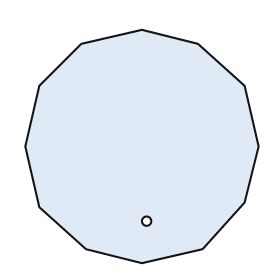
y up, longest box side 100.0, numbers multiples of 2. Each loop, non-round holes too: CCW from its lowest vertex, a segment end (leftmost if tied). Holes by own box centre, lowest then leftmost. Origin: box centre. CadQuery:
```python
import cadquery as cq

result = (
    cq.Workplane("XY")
    .moveTo(0.0, -50.0)
    .lineTo(26.0, -44.0)
    .lineTo(44.0, -24.0)
    .lineTo(50.0, 0.0)
    .lineTo(44.0, 26.0)
    .lineTo(24.0, 44.0)
    .lineTo(0.0, 50.0)
    .lineTo(-26.0, 44.0)
    .lineTo(-44.0, 26.0)
    .lineTo(-50.0, 0.0)
    .lineTo(-44.0, -26.0)
    .lineTo(-24.0, -44.0)
    .close()
    .moveTo(2.0, -32.0)
    .circle(2.0)
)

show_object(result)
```